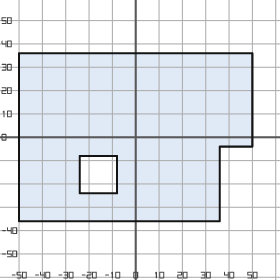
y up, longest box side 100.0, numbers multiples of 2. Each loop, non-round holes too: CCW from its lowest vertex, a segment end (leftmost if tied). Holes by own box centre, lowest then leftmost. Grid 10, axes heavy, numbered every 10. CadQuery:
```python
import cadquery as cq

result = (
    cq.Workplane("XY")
    .moveTo(-50.0, -36.0)
    .lineTo(36.0, -36.0)
    .lineTo(36.0, -4.0)
    .lineTo(50.0, -4.0)
    .lineTo(50.0, 36.0)
    .lineTo(-50.0, 36.0)
    .close()
    .moveTo(-24.0, -24.0)
    .lineTo(-8.0, -24.0)
    .lineTo(-8.0, -8.0)
    .lineTo(-24.0, -8.0)
    .close()
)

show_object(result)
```